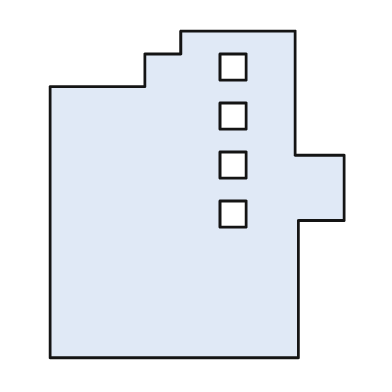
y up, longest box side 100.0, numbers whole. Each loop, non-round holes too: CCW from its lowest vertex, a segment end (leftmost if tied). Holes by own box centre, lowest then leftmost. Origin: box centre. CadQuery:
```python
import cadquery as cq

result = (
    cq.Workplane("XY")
    .moveTo(-45.0, -50.0)
    .lineTo(31.0, -50.0)
    .lineTo(31.0, -8.0)
    .lineTo(45.0, -8.0)
    .lineTo(45.0, 12.0)
    .lineTo(30.0, 12.0)
    .lineTo(30.0, 50.0)
    .lineTo(-5.0, 50.0)
    .lineTo(-5.0, 43.0)
    .lineTo(-16.0, 43.0)
    .lineTo(-16.0, 33.0)
    .lineTo(-45.0, 33.0)
    .close()
    .moveTo(7.0, -10.0)
    .lineTo(15.0, -10.0)
    .lineTo(15.0, -2.0)
    .lineTo(7.0, -2.0)
    .close()
    .moveTo(7.0, 5.0)
    .lineTo(15.0, 5.0)
    .lineTo(15.0, 13.0)
    .lineTo(7.0, 13.0)
    .close()
    .moveTo(7.0, 20.0)
    .lineTo(15.0, 20.0)
    .lineTo(15.0, 28.0)
    .lineTo(7.0, 28.0)
    .close()
    .moveTo(7.0, 35.0)
    .lineTo(15.0, 35.0)
    .lineTo(15.0, 43.0)
    .lineTo(7.0, 43.0)
    .close()
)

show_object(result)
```